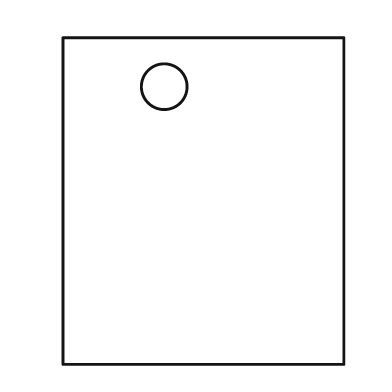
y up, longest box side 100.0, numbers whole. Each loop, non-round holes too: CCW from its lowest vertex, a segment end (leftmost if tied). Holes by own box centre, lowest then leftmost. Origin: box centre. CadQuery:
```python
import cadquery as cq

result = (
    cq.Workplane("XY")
    .moveTo(-43.0, -50.0)
    .lineTo(43.0, -50.0)
    .lineTo(43.0, 50.0)
    .lineTo(-43.0, 50.0)
    .close()
    .moveTo(-12.0, 35.0)
    .circle(7.0)
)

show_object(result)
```